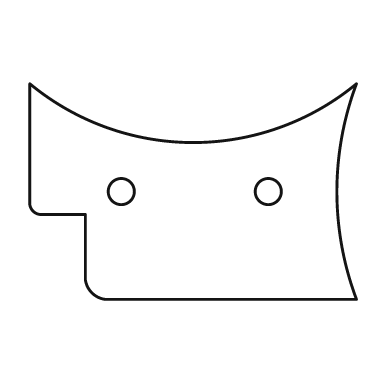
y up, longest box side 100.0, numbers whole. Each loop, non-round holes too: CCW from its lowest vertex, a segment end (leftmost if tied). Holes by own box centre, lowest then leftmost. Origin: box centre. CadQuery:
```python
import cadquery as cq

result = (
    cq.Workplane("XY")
    .moveTo(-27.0, -33.0)
    .lineTo(50.0, -33.0)
    .threePointArc((44.0, 0.0), (50.0, 33.0))
    .threePointArc((0.0, 15.0), (-50.0, 33.0))
    .lineTo(-50.0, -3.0)
    .threePointArc((-49.0, -6.0), (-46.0, -7.0))
    .lineTo(-33.0, -7.0)
    .lineTo(-33.0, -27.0)
    .threePointArc((-31.0, -31.0), (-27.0, -33.0))
    .close()
    .moveTo(-22.0, 0.0)
    .circle(4.0)
    .moveTo(23.0, 0.0)
    .circle(4.0)
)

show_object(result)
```